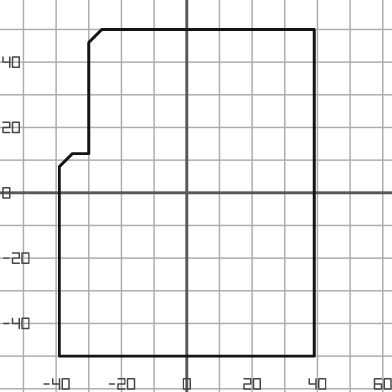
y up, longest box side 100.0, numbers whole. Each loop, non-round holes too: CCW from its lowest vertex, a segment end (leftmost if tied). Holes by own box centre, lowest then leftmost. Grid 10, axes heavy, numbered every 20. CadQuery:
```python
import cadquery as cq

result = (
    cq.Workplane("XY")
    .moveTo(-39.0, -50.0)
    .lineTo(39.0, -50.0)
    .lineTo(39.0, 50.0)
    .lineTo(-26.0, 50.0)
    .lineTo(-30.0, 46.0)
    .lineTo(-30.0, 12.0)
    .lineTo(-35.0, 12.0)
    .lineTo(-39.0, 8.0)
    .close()
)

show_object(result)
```